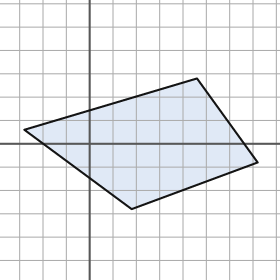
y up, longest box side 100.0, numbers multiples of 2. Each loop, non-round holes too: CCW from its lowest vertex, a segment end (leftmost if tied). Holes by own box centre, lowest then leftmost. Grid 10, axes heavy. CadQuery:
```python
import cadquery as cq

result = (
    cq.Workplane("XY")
    .moveTo(18.0, -28.0)
    .lineTo(72.0, -8.0)
    .lineTo(46.0, 28.0)
    .lineTo(-28.0, 6.0)
    .close()
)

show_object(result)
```